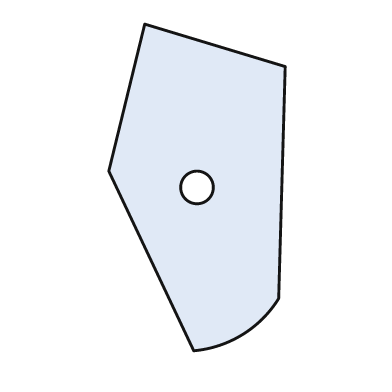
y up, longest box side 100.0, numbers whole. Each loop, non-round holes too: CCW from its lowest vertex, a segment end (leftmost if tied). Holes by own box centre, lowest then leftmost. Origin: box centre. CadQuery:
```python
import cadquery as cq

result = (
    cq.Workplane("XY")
    .moveTo(-1.0, -50.0)
    .threePointArc((14.0, -45.0), (25.0, -34.0))
    .lineTo(27.0, 37.0)
    .lineTo(-16.0, 50.0)
    .lineTo(-27.0, 5.0)
    .close()
    .moveTo(0.0, 0.0)
    .circle(5.0)
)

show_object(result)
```